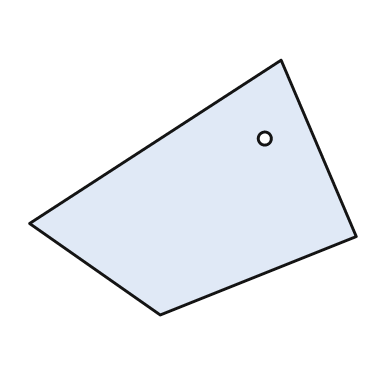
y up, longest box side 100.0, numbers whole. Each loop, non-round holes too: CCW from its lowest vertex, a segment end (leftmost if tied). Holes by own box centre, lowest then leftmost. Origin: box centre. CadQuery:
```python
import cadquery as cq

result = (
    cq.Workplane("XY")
    .moveTo(-10.0, -39.0)
    .lineTo(50.0, -15.0)
    .lineTo(27.0, 39.0)
    .lineTo(-50.0, -11.0)
    .close()
    .moveTo(22.0, 15.0)
    .circle(2.0)
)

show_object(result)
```